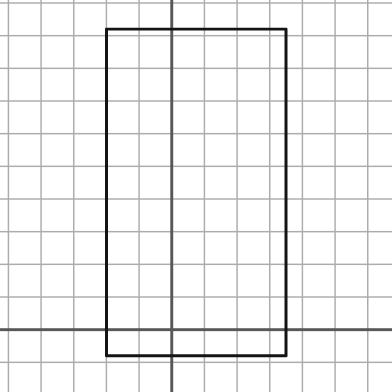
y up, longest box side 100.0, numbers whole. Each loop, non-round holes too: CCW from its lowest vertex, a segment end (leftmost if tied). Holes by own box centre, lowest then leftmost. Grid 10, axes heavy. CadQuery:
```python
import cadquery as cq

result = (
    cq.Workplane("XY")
    .moveTo(-20.0, -8.0)
    .lineTo(35.0, -8.0)
    .lineTo(35.0, 92.0)
    .lineTo(-20.0, 92.0)
    .close()
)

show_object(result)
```